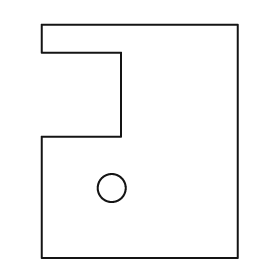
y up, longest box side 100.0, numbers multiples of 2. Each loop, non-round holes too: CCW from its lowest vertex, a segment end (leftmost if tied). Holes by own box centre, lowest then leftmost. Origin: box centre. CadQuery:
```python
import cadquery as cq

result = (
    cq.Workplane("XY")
    .moveTo(-42.0, -50.0)
    .lineTo(42.0, -50.0)
    .lineTo(42.0, 50.0)
    .lineTo(-42.0, 50.0)
    .lineTo(-42.0, 38.0)
    .lineTo(-8.0, 38.0)
    .lineTo(-8.0, 2.0)
    .lineTo(-42.0, 2.0)
    .close()
    .moveTo(-12.0, -20.0)
    .circle(6.0)
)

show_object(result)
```